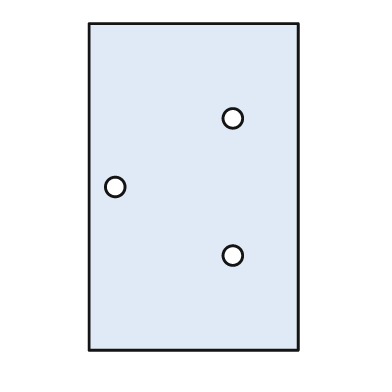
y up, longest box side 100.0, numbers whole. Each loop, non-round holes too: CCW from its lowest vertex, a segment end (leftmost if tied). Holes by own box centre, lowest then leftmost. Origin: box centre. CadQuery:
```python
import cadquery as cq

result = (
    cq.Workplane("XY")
    .moveTo(-32.0, -50.0)
    .lineTo(32.0, -50.0)
    .lineTo(32.0, 50.0)
    .lineTo(-32.0, 50.0)
    .close()
    .moveTo(12.0, -21.0)
    .circle(3.0)
    .moveTo(-24.0, 0.0)
    .circle(3.0)
    .moveTo(12.0, 21.0)
    .circle(3.0)
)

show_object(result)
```